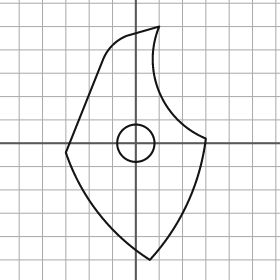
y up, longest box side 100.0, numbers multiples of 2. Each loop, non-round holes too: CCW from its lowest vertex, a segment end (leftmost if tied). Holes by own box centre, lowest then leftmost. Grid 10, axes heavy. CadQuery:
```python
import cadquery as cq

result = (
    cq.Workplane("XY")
    .moveTo(6.0, -50.0)
    .threePointArc((22.0, -26.0), (30.0, 2.0))
    .threePointArc((10.0, 22.0), (10.0, 50.0))
    .lineTo(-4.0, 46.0)
    .threePointArc((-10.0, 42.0), (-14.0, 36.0))
    .lineTo(-30.0, -4.0)
    .threePointArc((-16.0, -30.0), (6.0, -50.0))
    .close()
    .moveTo(0.0, 0.0)
    .circle(8.0)
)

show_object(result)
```